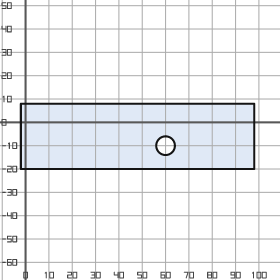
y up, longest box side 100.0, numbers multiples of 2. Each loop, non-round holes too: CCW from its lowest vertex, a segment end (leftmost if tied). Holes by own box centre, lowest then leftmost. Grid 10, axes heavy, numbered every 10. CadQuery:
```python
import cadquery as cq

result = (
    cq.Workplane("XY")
    .moveTo(-2.0, -20.0)
    .lineTo(98.0, -20.0)
    .lineTo(98.0, 8.0)
    .lineTo(-2.0, 8.0)
    .close()
    .moveTo(60.0, -10.0)
    .circle(4.0)
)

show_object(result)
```